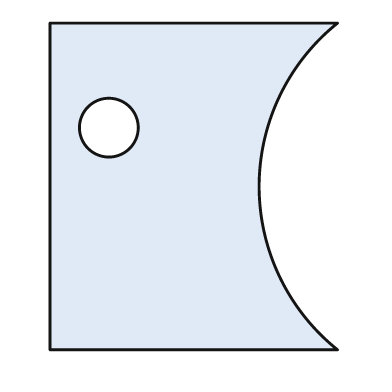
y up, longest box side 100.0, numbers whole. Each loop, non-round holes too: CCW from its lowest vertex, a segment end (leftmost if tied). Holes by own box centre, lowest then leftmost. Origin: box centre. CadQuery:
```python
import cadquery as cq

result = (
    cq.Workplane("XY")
    .moveTo(-44.0, -50.0)
    .lineTo(44.0, -50.0)
    .threePointArc((20.0, 0.0), (44.0, 50.0))
    .lineTo(-44.0, 50.0)
    .close()
    .moveTo(-26.0, 18.0)
    .circle(9.0)
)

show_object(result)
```